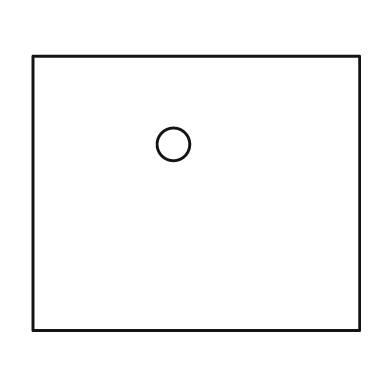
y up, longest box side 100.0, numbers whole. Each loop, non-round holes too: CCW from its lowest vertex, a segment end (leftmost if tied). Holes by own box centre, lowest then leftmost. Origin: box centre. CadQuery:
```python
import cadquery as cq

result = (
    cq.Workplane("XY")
    .moveTo(-50.0, -42.0)
    .lineTo(50.0, -42.0)
    .lineTo(50.0, 42.0)
    .lineTo(-50.0, 42.0)
    .close()
    .moveTo(-7.0, 15.0)
    .circle(5.0)
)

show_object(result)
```